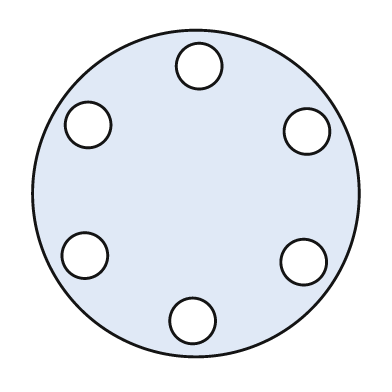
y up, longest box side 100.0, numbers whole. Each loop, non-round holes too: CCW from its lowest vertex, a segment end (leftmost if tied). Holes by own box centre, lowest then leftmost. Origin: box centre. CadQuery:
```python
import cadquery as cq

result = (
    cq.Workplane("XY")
    .moveTo(0.0, 0.0)
    .circle(50.0)
    .moveTo(-1.0, -39.0)
    .circle(7.0)
    .moveTo(33.0, -21.0)
    .circle(7.0)
    .moveTo(-34.0, -19.0)
    .circle(7.0)
    .moveTo(34.0, 19.0)
    .circle(7.0)
    .moveTo(-33.0, 21.0)
    .circle(7.0)
    .moveTo(1.0, 39.0)
    .circle(7.0)
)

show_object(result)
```